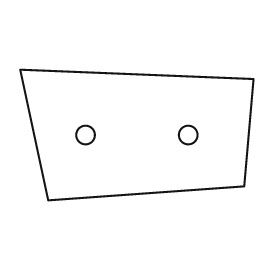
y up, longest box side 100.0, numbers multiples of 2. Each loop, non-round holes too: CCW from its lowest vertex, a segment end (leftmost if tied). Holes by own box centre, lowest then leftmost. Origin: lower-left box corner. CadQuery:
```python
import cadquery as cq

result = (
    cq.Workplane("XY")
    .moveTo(12.0, 0.0)
    .lineTo(96.0, 6.0)
    .lineTo(100.0, 52.0)
    .lineTo(0.0, 56.0)
    .close()
    .moveTo(28.0, 28.0)
    .circle(4.0)
    .moveTo(72.0, 28.0)
    .circle(4.0)
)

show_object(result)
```